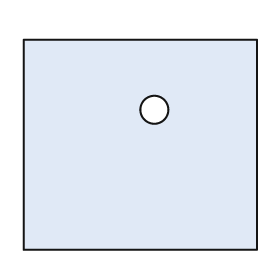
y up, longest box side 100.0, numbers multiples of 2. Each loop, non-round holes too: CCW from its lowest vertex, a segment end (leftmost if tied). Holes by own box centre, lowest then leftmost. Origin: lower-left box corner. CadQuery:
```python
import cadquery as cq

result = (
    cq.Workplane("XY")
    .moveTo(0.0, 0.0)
    .lineTo(100.0, 0.0)
    .lineTo(100.0, 90.0)
    .lineTo(0.0, 90.0)
    .close()
    .moveTo(56.0, 60.0)
    .circle(6.0)
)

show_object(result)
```